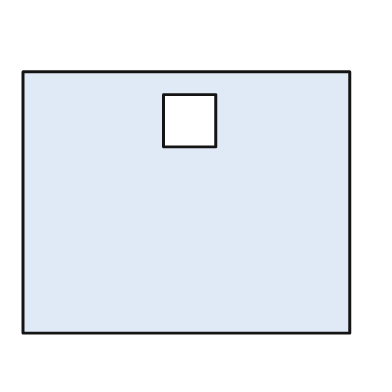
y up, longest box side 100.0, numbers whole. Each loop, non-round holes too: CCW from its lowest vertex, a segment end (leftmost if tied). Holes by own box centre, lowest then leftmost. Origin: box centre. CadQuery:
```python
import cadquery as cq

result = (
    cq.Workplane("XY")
    .moveTo(-50.0, -40.0)
    .lineTo(50.0, -40.0)
    .lineTo(50.0, 40.0)
    .lineTo(-50.0, 40.0)
    .close()
    .moveTo(-7.0, 17.0)
    .lineTo(9.0, 17.0)
    .lineTo(9.0, 33.0)
    .lineTo(-7.0, 33.0)
    .close()
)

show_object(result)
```